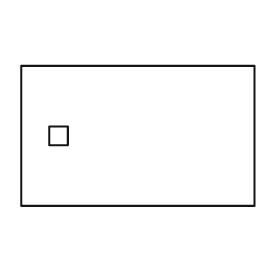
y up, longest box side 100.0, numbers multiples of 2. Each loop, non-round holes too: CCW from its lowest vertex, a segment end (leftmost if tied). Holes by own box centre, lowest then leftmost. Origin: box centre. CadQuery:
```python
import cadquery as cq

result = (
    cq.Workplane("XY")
    .moveTo(-50.0, -30.0)
    .lineTo(50.0, -30.0)
    .lineTo(50.0, 30.0)
    .lineTo(-50.0, 30.0)
    .close()
    .moveTo(-38.0, -4.0)
    .lineTo(-30.0, -4.0)
    .lineTo(-30.0, 4.0)
    .lineTo(-38.0, 4.0)
    .close()
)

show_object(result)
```